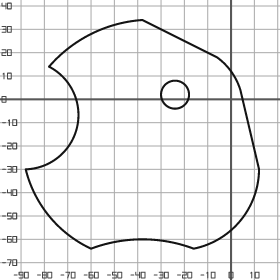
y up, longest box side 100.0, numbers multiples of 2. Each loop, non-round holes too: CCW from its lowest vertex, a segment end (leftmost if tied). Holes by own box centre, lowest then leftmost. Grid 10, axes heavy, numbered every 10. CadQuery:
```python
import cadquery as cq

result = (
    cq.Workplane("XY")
    .moveTo(-60.0, -64.0)
    .threePointArc((-38.0, -60.0), (-16.0, -64.0))
    .threePointArc((4.0, -52.0), (12.0, -30.0))
    .lineTo(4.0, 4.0)
    .threePointArc((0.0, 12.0), (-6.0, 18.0))
    .lineTo(-38.0, 34.0)
    .threePointArc((-60.0, 28.0), (-78.0, 14.0))
    .threePointArc((-66.0, -12.0), (-88.0, -30.0))
    .threePointArc((-78.0, -50.0), (-60.0, -64.0))
    .close()
    .moveTo(-24.0, 2.0)
    .circle(6.0)
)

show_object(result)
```